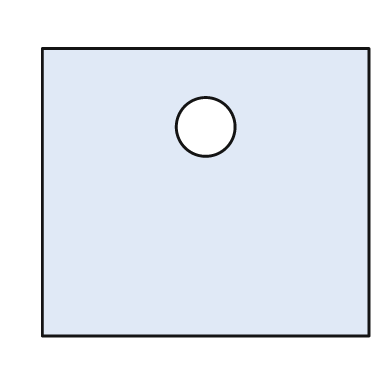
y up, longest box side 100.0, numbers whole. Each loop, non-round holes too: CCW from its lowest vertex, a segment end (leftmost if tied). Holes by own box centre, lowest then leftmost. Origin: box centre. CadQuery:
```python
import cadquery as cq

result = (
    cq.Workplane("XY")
    .moveTo(-50.0, -44.0)
    .lineTo(50.0, -44.0)
    .lineTo(50.0, 44.0)
    .lineTo(-50.0, 44.0)
    .close()
    .moveTo(0.0, 20.0)
    .circle(9.0)
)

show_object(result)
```